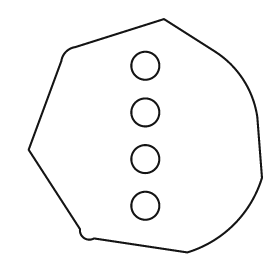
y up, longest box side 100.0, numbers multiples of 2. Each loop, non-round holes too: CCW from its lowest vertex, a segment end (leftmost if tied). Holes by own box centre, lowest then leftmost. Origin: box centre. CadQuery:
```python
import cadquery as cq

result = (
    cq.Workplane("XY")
    .moveTo(18.0, -50.0)
    .threePointArc((38.0, -38.0), (50.0, -18.0))
    .lineTo(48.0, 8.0)
    .threePointArc((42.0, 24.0), (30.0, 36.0))
    .lineTo(8.0, 50.0)
    .lineTo(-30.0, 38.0)
    .threePointArc((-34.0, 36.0), (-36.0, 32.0))
    .lineTo(-50.0, -6.0)
    .lineTo(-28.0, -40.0)
    .threePointArc((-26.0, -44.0), (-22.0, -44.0))
    .close()
    .moveTo(0.0, -30.0)
    .circle(6.0)
    .moveTo(0.0, -10.0)
    .circle(6.0)
    .moveTo(0.0, 10.0)
    .circle(6.0)
    .moveTo(0.0, 30.0)
    .circle(6.0)
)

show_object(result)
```